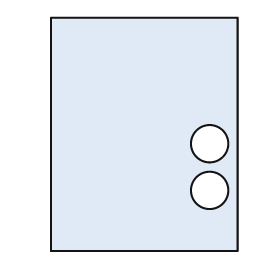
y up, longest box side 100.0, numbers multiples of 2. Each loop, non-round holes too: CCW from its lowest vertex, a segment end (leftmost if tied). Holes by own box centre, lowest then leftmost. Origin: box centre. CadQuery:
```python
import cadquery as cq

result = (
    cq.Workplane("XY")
    .moveTo(-40.0, -50.0)
    .lineTo(40.0, -50.0)
    .lineTo(40.0, 50.0)
    .lineTo(-40.0, 50.0)
    .close()
    .moveTo(28.0, -24.0)
    .circle(8.0)
    .moveTo(28.0, -4.0)
    .circle(8.0)
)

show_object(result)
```